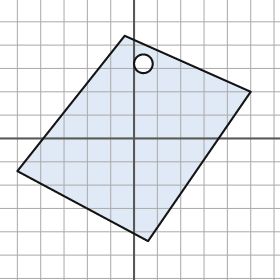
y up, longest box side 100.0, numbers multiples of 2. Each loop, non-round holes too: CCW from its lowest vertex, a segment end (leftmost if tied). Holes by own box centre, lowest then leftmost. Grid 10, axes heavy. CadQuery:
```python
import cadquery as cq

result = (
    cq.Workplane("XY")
    .moveTo(6.0, -44.0)
    .lineTo(50.0, 20.0)
    .lineTo(-4.0, 44.0)
    .lineTo(-50.0, -14.0)
    .close()
    .moveTo(4.0, 32.0)
    .circle(4.0)
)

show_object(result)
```